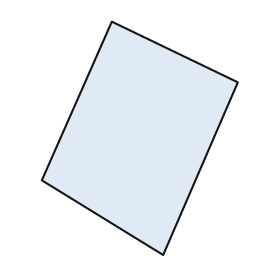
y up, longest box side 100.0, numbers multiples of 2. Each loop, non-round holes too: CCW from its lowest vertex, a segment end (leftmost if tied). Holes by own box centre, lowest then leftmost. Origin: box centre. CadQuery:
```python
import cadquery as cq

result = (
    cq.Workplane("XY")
    .moveTo(10.0, -50.0)
    .lineTo(42.0, 24.0)
    .lineTo(-12.0, 50.0)
    .lineTo(-42.0, -18.0)
    .close()
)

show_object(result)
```